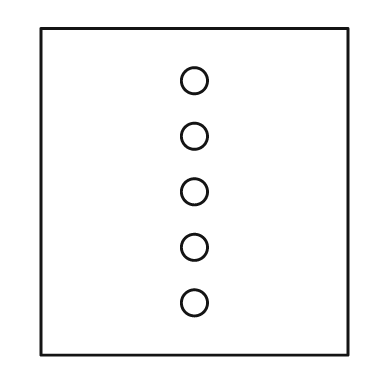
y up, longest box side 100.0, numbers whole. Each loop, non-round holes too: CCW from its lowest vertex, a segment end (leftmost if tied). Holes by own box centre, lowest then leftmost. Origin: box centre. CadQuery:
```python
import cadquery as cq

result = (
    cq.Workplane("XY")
    .moveTo(-47.0, -50.0)
    .lineTo(47.0, -50.0)
    .lineTo(47.0, 50.0)
    .lineTo(-47.0, 50.0)
    .close()
    .moveTo(0.0, -34.0)
    .circle(4.0)
    .moveTo(0.0, -17.0)
    .circle(4.0)
    .moveTo(0.0, 0.0)
    .circle(4.0)
    .moveTo(0.0, 17.0)
    .circle(4.0)
    .moveTo(0.0, 34.0)
    .circle(4.0)
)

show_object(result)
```